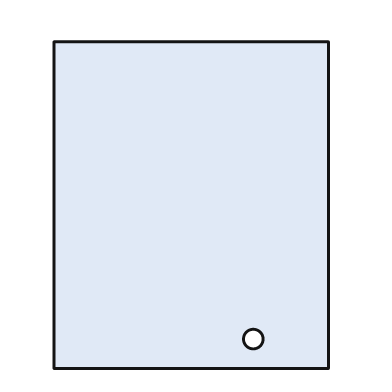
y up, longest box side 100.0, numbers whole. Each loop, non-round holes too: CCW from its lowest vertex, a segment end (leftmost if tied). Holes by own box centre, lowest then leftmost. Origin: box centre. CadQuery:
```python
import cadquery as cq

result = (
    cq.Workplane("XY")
    .moveTo(-42.0, -50.0)
    .lineTo(42.0, -50.0)
    .lineTo(42.0, 50.0)
    .lineTo(-42.0, 50.0)
    .close()
    .moveTo(19.0, -41.0)
    .circle(3.0)
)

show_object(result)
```